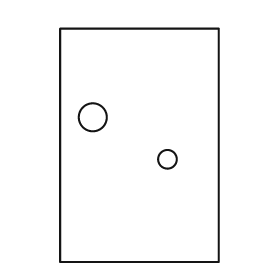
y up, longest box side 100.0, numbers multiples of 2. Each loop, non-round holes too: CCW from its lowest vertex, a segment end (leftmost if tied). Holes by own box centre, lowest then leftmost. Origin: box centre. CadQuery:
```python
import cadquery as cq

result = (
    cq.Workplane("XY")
    .moveTo(-34.0, -50.0)
    .lineTo(34.0, -50.0)
    .lineTo(34.0, 50.0)
    .lineTo(-34.0, 50.0)
    .close()
    .moveTo(12.0, -6.0)
    .circle(4.0)
    .moveTo(-20.0, 12.0)
    .circle(6.0)
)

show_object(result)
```